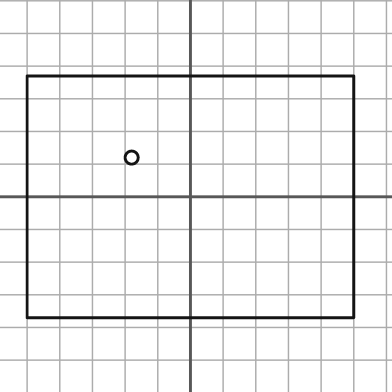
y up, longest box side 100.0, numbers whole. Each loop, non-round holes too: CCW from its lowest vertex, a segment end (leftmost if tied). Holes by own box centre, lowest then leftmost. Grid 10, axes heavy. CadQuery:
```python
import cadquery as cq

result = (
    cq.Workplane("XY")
    .moveTo(-50.0, -37.0)
    .lineTo(50.0, -37.0)
    .lineTo(50.0, 37.0)
    .lineTo(-50.0, 37.0)
    .close()
    .moveTo(-18.0, 12.0)
    .circle(2.0)
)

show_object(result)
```